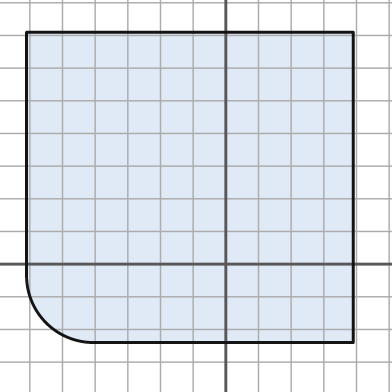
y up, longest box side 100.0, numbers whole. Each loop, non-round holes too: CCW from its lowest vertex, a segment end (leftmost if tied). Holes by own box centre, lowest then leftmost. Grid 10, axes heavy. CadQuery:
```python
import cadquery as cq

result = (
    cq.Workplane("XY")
    .moveTo(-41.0, -24.0)
    .lineTo(39.0, -24.0)
    .lineTo(39.0, 71.0)
    .lineTo(-61.0, 71.0)
    .lineTo(-61.0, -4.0)
    .threePointArc((-55.0, -18.0), (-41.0, -24.0))
    .close()
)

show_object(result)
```